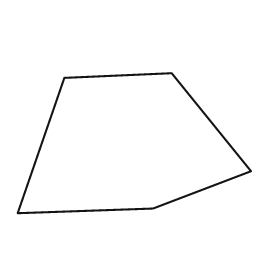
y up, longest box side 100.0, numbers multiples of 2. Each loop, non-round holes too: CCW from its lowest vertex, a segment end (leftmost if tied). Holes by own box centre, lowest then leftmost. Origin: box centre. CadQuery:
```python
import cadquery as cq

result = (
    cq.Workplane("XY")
    .moveTo(-50.0, -30.0)
    .lineTo(8.0, -28.0)
    .lineTo(50.0, -12.0)
    .lineTo(16.0, 30.0)
    .lineTo(-30.0, 28.0)
    .close()
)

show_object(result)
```